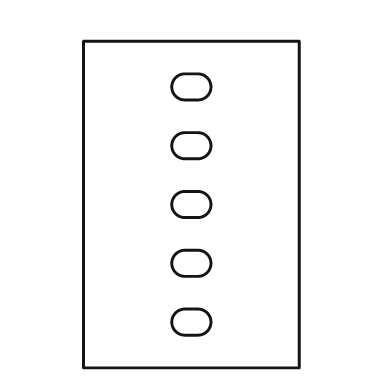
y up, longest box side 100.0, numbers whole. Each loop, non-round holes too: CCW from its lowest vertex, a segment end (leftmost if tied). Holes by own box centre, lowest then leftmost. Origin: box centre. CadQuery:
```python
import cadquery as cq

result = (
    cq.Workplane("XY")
    .moveTo(-33.0, -50.0)
    .lineTo(33.0, -50.0)
    .lineTo(33.0, 50.0)
    .lineTo(-33.0, 50.0)
    .close()
    .moveTo(-2.0, -40.0)
    .lineTo(2.0, -40.0)
    .threePointArc((6.0, -36.0), (2.0, -32.0))
    .lineTo(-2.0, -32.0)
    .threePointArc((-6.0, -36.0), (-2.0, -40.0))
    .close()
    .moveTo(-2.0, -22.0)
    .lineTo(2.0, -22.0)
    .threePointArc((6.0, -18.0), (2.0, -14.0))
    .lineTo(-2.0, -14.0)
    .threePointArc((-6.0, -18.0), (-2.0, -22.0))
    .close()
    .moveTo(-2.0, -4.0)
    .lineTo(2.0, -4.0)
    .threePointArc((6.0, 0.0), (2.0, 4.0))
    .lineTo(-2.0, 4.0)
    .threePointArc((-6.0, 0.0), (-2.0, -4.0))
    .close()
    .moveTo(-2.0, 14.0)
    .lineTo(2.0, 14.0)
    .threePointArc((6.0, 18.0), (2.0, 22.0))
    .lineTo(-2.0, 22.0)
    .threePointArc((-6.0, 18.0), (-2.0, 14.0))
    .close()
    .moveTo(-2.0, 32.0)
    .lineTo(2.0, 32.0)
    .threePointArc((6.0, 36.0), (2.0, 40.0))
    .lineTo(-2.0, 40.0)
    .threePointArc((-6.0, 36.0), (-2.0, 32.0))
    .close()
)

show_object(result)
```